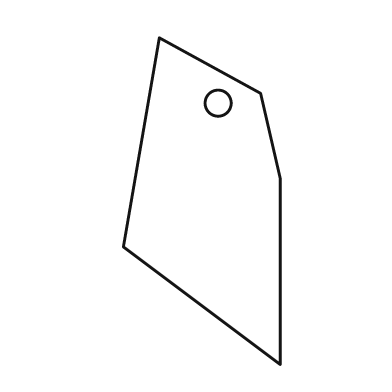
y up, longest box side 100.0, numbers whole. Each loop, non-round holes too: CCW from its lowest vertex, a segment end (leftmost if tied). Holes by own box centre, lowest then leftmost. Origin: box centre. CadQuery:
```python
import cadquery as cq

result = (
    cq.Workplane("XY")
    .moveTo(24.0, -50.0)
    .lineTo(24.0, 7.0)
    .lineTo(18.0, 33.0)
    .lineTo(-13.0, 50.0)
    .lineTo(-24.0, -14.0)
    .close()
    .moveTo(5.0, 30.0)
    .circle(4.0)
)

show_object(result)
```